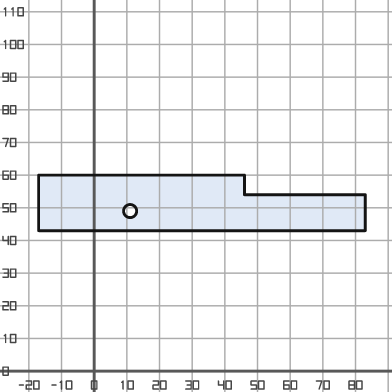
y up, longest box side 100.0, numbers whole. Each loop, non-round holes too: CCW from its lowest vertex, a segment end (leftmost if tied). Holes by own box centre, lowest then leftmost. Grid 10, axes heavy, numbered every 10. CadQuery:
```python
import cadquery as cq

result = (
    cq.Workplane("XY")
    .moveTo(-17.0, 43.0)
    .lineTo(83.0, 43.0)
    .lineTo(83.0, 54.0)
    .lineTo(46.0, 54.0)
    .lineTo(46.0, 60.0)
    .lineTo(-17.0, 60.0)
    .close()
    .moveTo(11.0, 49.0)
    .circle(2.0)
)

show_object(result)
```